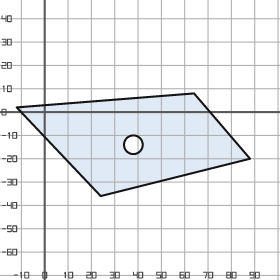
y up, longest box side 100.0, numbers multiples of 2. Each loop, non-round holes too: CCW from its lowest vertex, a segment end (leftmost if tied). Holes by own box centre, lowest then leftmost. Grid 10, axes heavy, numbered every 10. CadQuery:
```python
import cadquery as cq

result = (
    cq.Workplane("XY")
    .moveTo(24.0, -36.0)
    .lineTo(88.0, -20.0)
    .lineTo(64.0, 8.0)
    .lineTo(-12.0, 2.0)
    .close()
    .moveTo(38.0, -14.0)
    .circle(4.0)
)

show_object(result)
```